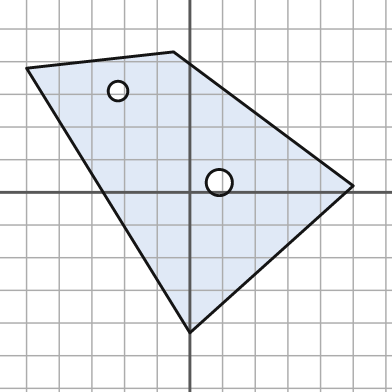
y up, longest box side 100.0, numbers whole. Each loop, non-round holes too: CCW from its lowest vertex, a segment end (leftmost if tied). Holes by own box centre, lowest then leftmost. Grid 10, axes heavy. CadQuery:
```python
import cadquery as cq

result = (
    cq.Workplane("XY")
    .moveTo(0.0, -43.0)
    .lineTo(50.0, 2.0)
    .lineTo(-5.0, 43.0)
    .lineTo(-50.0, 38.0)
    .close()
    .moveTo(9.0, 3.0)
    .circle(4.0)
    .moveTo(-22.0, 31.0)
    .circle(3.0)
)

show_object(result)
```